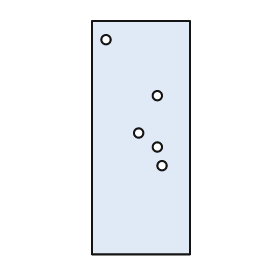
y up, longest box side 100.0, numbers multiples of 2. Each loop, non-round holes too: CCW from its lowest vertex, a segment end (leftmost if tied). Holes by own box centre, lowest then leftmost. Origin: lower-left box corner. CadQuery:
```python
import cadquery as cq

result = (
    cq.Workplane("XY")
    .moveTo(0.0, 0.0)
    .lineTo(42.0, 0.0)
    .lineTo(42.0, 100.0)
    .lineTo(0.0, 100.0)
    .close()
    .moveTo(30.0, 38.0)
    .circle(2.0)
    .moveTo(28.0, 46.0)
    .circle(2.0)
    .moveTo(20.0, 52.0)
    .circle(2.0)
    .moveTo(28.0, 68.0)
    .circle(2.0)
    .moveTo(6.0, 92.0)
    .circle(2.0)
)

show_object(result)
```